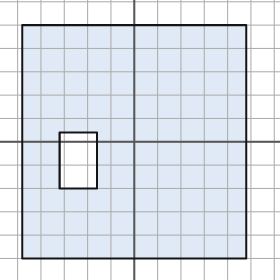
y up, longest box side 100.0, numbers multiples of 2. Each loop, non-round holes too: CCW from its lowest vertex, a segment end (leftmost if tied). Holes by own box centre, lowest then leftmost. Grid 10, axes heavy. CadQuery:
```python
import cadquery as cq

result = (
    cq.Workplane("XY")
    .moveTo(-48.0, -50.0)
    .lineTo(48.0, -50.0)
    .lineTo(48.0, 50.0)
    .lineTo(-48.0, 50.0)
    .close()
    .moveTo(-32.0, -20.0)
    .lineTo(-16.0, -20.0)
    .lineTo(-16.0, 4.0)
    .lineTo(-32.0, 4.0)
    .close()
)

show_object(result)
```